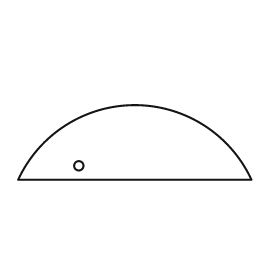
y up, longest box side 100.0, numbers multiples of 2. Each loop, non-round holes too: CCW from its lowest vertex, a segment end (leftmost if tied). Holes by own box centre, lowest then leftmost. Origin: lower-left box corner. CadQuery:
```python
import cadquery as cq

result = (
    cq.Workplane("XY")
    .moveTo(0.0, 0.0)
    .lineTo(100.0, 0.0)
    .threePointArc((50.0, 32.0), (0.0, 0.0))
    .close()
    .moveTo(26.0, 6.0)
    .circle(2.0)
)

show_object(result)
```